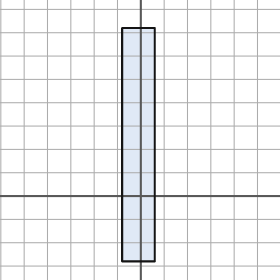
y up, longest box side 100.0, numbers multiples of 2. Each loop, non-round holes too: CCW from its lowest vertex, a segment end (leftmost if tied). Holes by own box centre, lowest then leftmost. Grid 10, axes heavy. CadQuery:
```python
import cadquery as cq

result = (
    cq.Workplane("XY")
    .moveTo(-8.0, -28.0)
    .lineTo(6.0, -28.0)
    .lineTo(6.0, 72.0)
    .lineTo(-8.0, 72.0)
    .close()
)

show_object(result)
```